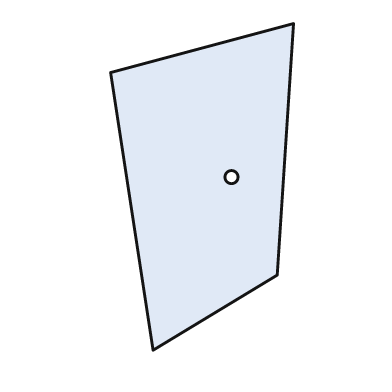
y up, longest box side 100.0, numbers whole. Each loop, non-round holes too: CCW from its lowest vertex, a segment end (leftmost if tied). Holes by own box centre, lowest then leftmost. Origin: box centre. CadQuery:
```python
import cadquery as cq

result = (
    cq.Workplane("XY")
    .moveTo(-15.0, -50.0)
    .lineTo(23.0, -27.0)
    .lineTo(28.0, 50.0)
    .lineTo(-28.0, 35.0)
    .close()
    .moveTo(9.0, 3.0)
    .circle(2.0)
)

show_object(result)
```